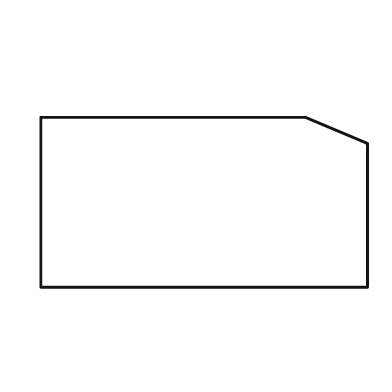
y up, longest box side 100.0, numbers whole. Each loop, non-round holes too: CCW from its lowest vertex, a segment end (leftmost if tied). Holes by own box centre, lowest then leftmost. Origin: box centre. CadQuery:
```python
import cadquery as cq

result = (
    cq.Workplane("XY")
    .moveTo(-50.0, -26.0)
    .lineTo(50.0, -26.0)
    .lineTo(50.0, 18.0)
    .lineTo(31.0, 26.0)
    .lineTo(-50.0, 26.0)
    .close()
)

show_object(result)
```